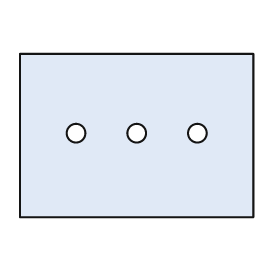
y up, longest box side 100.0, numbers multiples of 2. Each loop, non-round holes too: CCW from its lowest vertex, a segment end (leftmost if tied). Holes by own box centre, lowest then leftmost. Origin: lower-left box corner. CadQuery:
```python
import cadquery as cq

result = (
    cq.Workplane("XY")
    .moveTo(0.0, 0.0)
    .lineTo(100.0, 0.0)
    .lineTo(100.0, 70.0)
    .lineTo(0.0, 70.0)
    .close()
    .moveTo(24.0, 36.0)
    .circle(4.0)
    .moveTo(50.0, 36.0)
    .circle(4.0)
    .moveTo(76.0, 36.0)
    .circle(4.0)
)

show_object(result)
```